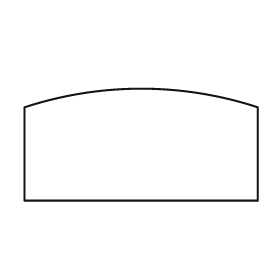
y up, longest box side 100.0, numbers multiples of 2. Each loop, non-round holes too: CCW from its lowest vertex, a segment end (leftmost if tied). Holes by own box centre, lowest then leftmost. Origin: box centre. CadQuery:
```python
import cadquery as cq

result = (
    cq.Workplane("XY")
    .moveTo(-50.0, -24.0)
    .lineTo(50.0, -24.0)
    .lineTo(50.0, 16.0)
    .threePointArc((0.0, 24.0), (-50.0, 16.0))
    .close()
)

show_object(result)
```